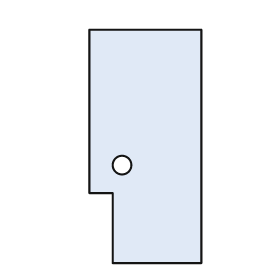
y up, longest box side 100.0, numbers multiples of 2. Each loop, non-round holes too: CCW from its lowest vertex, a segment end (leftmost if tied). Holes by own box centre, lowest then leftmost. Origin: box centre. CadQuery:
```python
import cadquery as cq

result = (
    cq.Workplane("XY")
    .moveTo(-14.0, -50.0)
    .lineTo(24.0, -50.0)
    .lineTo(24.0, 50.0)
    .lineTo(-24.0, 50.0)
    .lineTo(-24.0, -20.0)
    .lineTo(-14.0, -20.0)
    .close()
    .moveTo(-10.0, -8.0)
    .circle(4.0)
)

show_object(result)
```